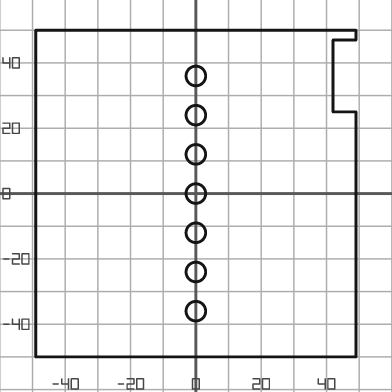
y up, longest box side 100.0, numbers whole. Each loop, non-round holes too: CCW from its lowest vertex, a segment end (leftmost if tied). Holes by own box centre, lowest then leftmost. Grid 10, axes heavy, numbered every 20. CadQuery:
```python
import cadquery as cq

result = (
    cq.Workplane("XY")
    .moveTo(-49.0, -50.0)
    .lineTo(49.0, -50.0)
    .lineTo(49.0, 25.0)
    .lineTo(42.0, 25.0)
    .lineTo(42.0, 47.0)
    .lineTo(49.0, 47.0)
    .lineTo(49.0, 50.0)
    .lineTo(-49.0, 50.0)
    .close()
    .moveTo(0.0, -36.0)
    .circle(3.0)
    .moveTo(0.0, -24.0)
    .circle(3.0)
    .moveTo(0.0, -12.0)
    .circle(3.0)
    .moveTo(0.0, 0.0)
    .circle(3.0)
    .moveTo(0.0, 12.0)
    .circle(3.0)
    .moveTo(0.0, 24.0)
    .circle(3.0)
    .moveTo(0.0, 36.0)
    .circle(3.0)
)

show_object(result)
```